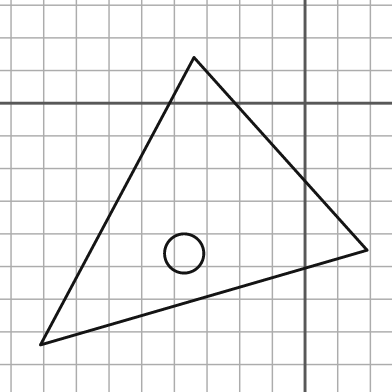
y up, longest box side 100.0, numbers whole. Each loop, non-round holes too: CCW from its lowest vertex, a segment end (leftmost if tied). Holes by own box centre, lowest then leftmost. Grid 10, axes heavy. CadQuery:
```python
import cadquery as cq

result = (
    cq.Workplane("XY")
    .moveTo(-81.0, -74.0)
    .lineTo(19.0, -45.0)
    .lineTo(-34.0, 14.0)
    .close()
    .moveTo(-37.0, -46.0)
    .circle(6.0)
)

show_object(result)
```